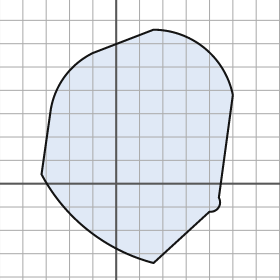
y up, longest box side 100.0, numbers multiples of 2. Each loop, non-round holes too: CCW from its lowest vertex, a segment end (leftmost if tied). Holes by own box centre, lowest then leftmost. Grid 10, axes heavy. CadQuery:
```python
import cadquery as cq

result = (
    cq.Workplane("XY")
    .moveTo(16.0, -34.0)
    .lineTo(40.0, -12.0)
    .threePointArc((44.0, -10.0), (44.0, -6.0))
    .lineTo(50.0, 38.0)
    .threePointArc((38.0, 58.0), (16.0, 66.0))
    .lineTo(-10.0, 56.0)
    .threePointArc((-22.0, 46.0), (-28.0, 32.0))
    .lineTo(-32.0, 4.0)
    .threePointArc((-12.0, -20.0), (16.0, -34.0))
    .close()
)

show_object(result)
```